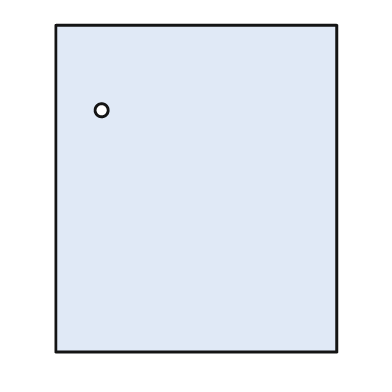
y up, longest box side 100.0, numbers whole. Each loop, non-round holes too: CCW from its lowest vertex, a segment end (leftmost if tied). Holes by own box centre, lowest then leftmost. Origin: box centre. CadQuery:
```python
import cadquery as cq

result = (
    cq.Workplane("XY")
    .moveTo(-43.0, -50.0)
    .lineTo(43.0, -50.0)
    .lineTo(43.0, 50.0)
    .lineTo(-43.0, 50.0)
    .close()
    .moveTo(-29.0, 24.0)
    .circle(2.0)
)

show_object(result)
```